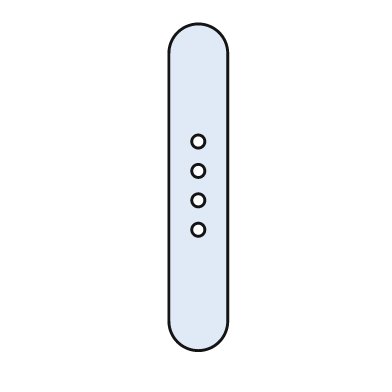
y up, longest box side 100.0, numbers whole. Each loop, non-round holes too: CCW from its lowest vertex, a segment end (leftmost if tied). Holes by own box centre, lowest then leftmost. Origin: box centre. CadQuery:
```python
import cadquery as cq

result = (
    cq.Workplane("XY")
    .moveTo(-9.0, -41.0)
    .threePointArc((0.0, -50.0), (9.0, -41.0))
    .lineTo(9.0, 41.0)
    .threePointArc((0.0, 50.0), (-9.0, 41.0))
    .close()
    .moveTo(0.0, -13.0)
    .circle(2.0)
    .moveTo(0.0, -4.0)
    .circle(2.0)
    .moveTo(0.0, 5.0)
    .circle(2.0)
    .moveTo(0.0, 14.0)
    .circle(2.0)
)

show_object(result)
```